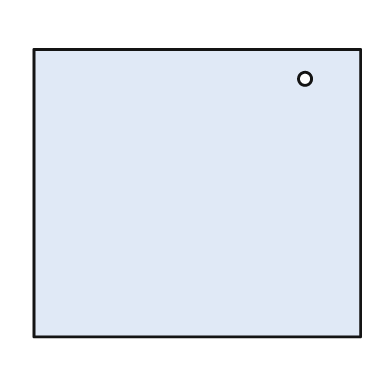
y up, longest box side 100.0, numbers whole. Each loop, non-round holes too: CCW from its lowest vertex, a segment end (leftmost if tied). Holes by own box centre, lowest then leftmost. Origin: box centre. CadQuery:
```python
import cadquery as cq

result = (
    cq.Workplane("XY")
    .moveTo(-50.0, -44.0)
    .lineTo(50.0, -44.0)
    .lineTo(50.0, 44.0)
    .lineTo(-50.0, 44.0)
    .close()
    .moveTo(33.0, 35.0)
    .circle(2.0)
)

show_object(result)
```